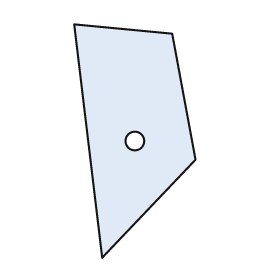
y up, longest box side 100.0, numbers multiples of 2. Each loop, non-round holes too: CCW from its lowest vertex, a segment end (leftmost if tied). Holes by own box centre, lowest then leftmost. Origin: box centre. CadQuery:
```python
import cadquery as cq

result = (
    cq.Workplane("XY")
    .moveTo(-14.0, -50.0)
    .lineTo(26.0, -8.0)
    .lineTo(16.0, 46.0)
    .lineTo(-26.0, 50.0)
    .close()
    .moveTo(0.0, 0.0)
    .circle(4.0)
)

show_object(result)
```